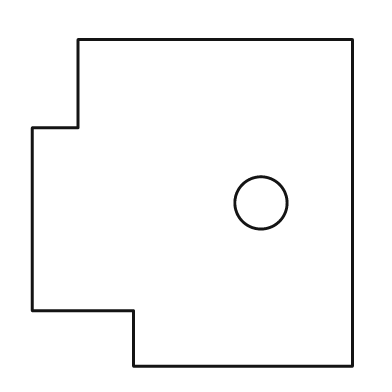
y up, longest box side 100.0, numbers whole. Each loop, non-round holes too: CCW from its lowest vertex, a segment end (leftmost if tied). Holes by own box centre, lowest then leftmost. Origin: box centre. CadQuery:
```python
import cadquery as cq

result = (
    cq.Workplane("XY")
    .moveTo(-18.0, -50.0)
    .lineTo(49.0, -50.0)
    .lineTo(49.0, 50.0)
    .lineTo(-35.0, 50.0)
    .lineTo(-35.0, 23.0)
    .lineTo(-49.0, 23.0)
    .lineTo(-49.0, -33.0)
    .lineTo(-18.0, -33.0)
    .close()
    .moveTo(21.0, 0.0)
    .circle(8.0)
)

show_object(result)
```